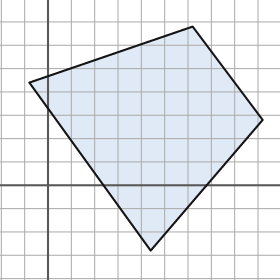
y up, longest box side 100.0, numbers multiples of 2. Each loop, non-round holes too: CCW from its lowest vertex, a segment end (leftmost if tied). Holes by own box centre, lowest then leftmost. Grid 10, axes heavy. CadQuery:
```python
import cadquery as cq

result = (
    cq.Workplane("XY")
    .moveTo(44.0, -28.0)
    .lineTo(92.0, 28.0)
    .lineTo(62.0, 68.0)
    .lineTo(-8.0, 44.0)
    .close()
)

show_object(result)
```